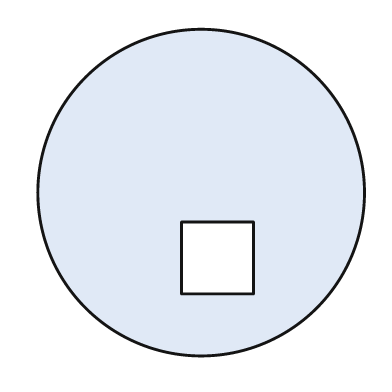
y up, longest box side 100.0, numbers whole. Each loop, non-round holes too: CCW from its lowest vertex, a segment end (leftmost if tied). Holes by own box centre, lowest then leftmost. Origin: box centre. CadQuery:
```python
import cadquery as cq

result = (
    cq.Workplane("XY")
    .moveTo(0.0, 0.0)
    .circle(50.0)
    .moveTo(-6.0, -31.0)
    .lineTo(16.0, -31.0)
    .lineTo(16.0, -9.0)
    .lineTo(-6.0, -9.0)
    .close()
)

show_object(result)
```